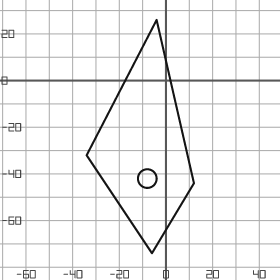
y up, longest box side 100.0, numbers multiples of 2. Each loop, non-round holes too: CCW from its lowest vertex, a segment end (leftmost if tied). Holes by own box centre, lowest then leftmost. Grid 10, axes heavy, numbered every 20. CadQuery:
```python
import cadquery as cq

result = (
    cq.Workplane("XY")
    .moveTo(-6.0, -74.0)
    .lineTo(12.0, -44.0)
    .lineTo(-4.0, 26.0)
    .lineTo(-34.0, -32.0)
    .close()
    .moveTo(-8.0, -42.0)
    .circle(4.0)
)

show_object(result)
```